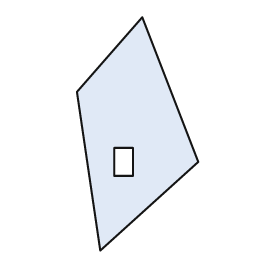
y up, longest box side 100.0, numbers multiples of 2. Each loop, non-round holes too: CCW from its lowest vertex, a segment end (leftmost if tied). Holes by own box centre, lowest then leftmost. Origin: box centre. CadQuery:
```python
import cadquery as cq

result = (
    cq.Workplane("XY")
    .moveTo(-16.0, -50.0)
    .lineTo(26.0, -12.0)
    .lineTo(2.0, 50.0)
    .lineTo(-26.0, 18.0)
    .close()
    .moveTo(-10.0, -18.0)
    .lineTo(-2.0, -18.0)
    .lineTo(-2.0, -6.0)
    .lineTo(-10.0, -6.0)
    .close()
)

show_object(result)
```